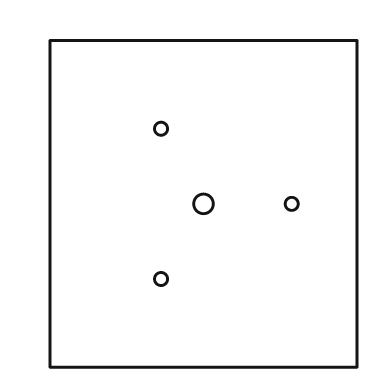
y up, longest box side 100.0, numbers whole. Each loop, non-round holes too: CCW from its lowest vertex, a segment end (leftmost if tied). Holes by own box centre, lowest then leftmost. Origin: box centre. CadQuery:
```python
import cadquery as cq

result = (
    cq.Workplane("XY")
    .moveTo(-47.0, -50.0)
    .lineTo(47.0, -50.0)
    .lineTo(47.0, 50.0)
    .lineTo(-47.0, 50.0)
    .close()
    .moveTo(-13.0, -23.0)
    .circle(2.0)
    .moveTo(0.0, 0.0)
    .circle(3.0)
    .moveTo(27.0, 0.0)
    .circle(2.0)
    .moveTo(-13.0, 23.0)
    .circle(2.0)
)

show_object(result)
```